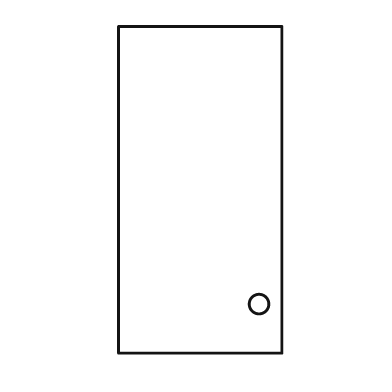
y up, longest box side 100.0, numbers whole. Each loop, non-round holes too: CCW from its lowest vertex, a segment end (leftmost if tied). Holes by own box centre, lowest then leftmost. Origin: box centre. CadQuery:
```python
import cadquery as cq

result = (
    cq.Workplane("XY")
    .moveTo(-25.0, -50.0)
    .lineTo(25.0, -50.0)
    .lineTo(25.0, 50.0)
    .lineTo(-25.0, 50.0)
    .close()
    .moveTo(18.0, -35.0)
    .circle(3.0)
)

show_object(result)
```